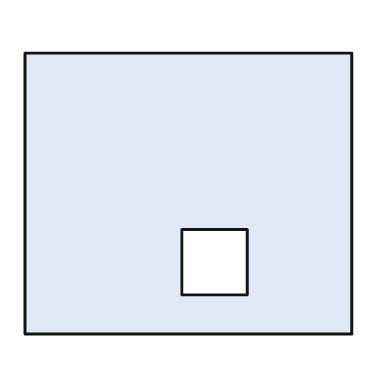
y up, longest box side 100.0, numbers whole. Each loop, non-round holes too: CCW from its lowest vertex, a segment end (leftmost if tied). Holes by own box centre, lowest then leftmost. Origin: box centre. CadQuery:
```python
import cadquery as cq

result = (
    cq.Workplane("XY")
    .moveTo(-50.0, -43.0)
    .lineTo(50.0, -43.0)
    .lineTo(50.0, 43.0)
    .lineTo(-50.0, 43.0)
    .close()
    .moveTo(-2.0, -31.0)
    .lineTo(18.0, -31.0)
    .lineTo(18.0, -11.0)
    .lineTo(-2.0, -11.0)
    .close()
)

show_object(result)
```